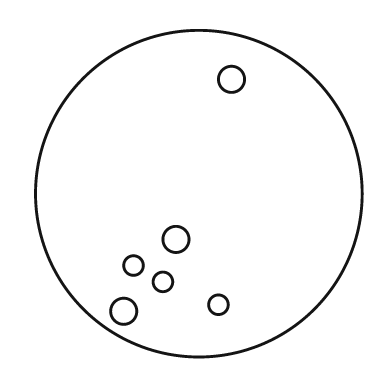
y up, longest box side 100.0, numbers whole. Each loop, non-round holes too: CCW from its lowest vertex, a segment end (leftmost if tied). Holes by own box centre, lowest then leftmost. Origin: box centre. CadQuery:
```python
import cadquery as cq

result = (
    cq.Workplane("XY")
    .moveTo(0.0, 0.0)
    .circle(50.0)
    .moveTo(-23.0, -36.0)
    .circle(4.0)
    .moveTo(6.0, -34.0)
    .circle(3.0)
    .moveTo(-11.0, -27.0)
    .circle(3.0)
    .moveTo(-20.0, -22.0)
    .circle(3.0)
    .moveTo(-7.0, -14.0)
    .circle(4.0)
    .moveTo(10.0, 35.0)
    .circle(4.0)
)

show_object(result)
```